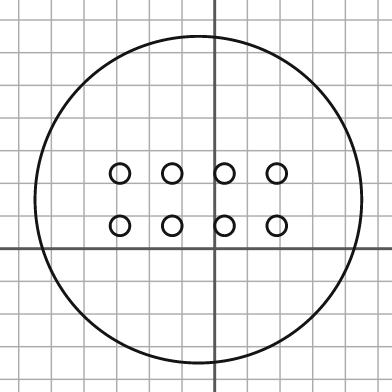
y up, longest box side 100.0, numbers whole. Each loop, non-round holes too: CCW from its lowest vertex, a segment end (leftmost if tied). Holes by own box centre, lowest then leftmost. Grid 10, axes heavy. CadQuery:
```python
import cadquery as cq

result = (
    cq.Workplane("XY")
    .moveTo(-5.0, 15.0)
    .circle(50.0)
    .moveTo(-29.0, 7.0)
    .circle(3.0)
    .moveTo(-13.0, 7.0)
    .circle(3.0)
    .moveTo(3.0, 7.0)
    .circle(3.0)
    .moveTo(19.0, 7.0)
    .circle(3.0)
    .moveTo(-29.0, 23.0)
    .circle(3.0)
    .moveTo(-13.0, 23.0)
    .circle(3.0)
    .moveTo(3.0, 23.0)
    .circle(3.0)
    .moveTo(19.0, 23.0)
    .circle(3.0)
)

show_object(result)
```